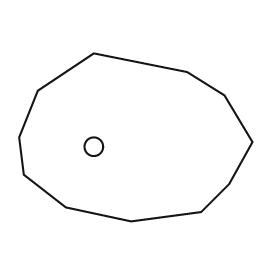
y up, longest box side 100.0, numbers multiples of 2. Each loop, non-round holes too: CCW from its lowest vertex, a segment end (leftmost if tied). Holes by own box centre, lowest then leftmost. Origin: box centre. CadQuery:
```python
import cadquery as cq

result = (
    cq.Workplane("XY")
    .moveTo(-2.0, -36.0)
    .lineTo(28.0, -32.0)
    .lineTo(40.0, -20.0)
    .lineTo(50.0, -2.0)
    .lineTo(38.0, 18.0)
    .lineTo(22.0, 28.0)
    .lineTo(-18.0, 36.0)
    .lineTo(-42.0, 20.0)
    .lineTo(-50.0, 0.0)
    .lineTo(-48.0, -16.0)
    .lineTo(-30.0, -30.0)
    .close()
    .moveTo(-18.0, -4.0)
    .circle(4.0)
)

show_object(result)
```